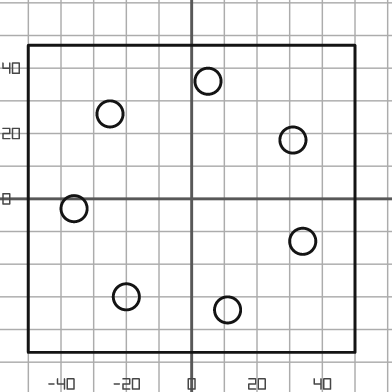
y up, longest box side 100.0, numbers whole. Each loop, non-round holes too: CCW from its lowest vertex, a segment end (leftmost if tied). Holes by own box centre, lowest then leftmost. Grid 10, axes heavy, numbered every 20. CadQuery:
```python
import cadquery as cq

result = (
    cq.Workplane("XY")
    .moveTo(-50.0, -47.0)
    .lineTo(50.0, -47.0)
    .lineTo(50.0, 47.0)
    .lineTo(-50.0, 47.0)
    .close()
    .moveTo(11.0, -34.0)
    .circle(4.0)
    .moveTo(-20.0, -30.0)
    .circle(4.0)
    .moveTo(34.0, -13.0)
    .circle(4.0)
    .moveTo(-36.0, -3.0)
    .circle(4.0)
    .moveTo(31.0, 18.0)
    .circle(4.0)
    .moveTo(-25.0, 26.0)
    .circle(4.0)
    .moveTo(5.0, 36.0)
    .circle(4.0)
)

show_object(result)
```